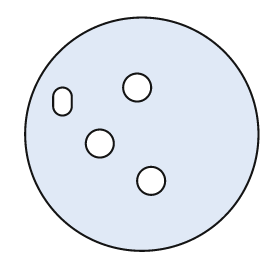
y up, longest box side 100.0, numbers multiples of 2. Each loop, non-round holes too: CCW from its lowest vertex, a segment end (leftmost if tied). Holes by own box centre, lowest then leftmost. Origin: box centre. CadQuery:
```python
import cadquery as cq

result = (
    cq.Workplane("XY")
    .moveTo(0.0, 0.0)
    .circle(50.0)
    .moveTo(4.0, -20.0)
    .circle(6.0)
    .moveTo(-18.0, -4.0)
    .circle(6.0)
    .moveTo(-38.0, 12.0)
    .threePointArc((-34.0, 8.0), (-30.0, 12.0))
    .lineTo(-30.0, 16.0)
    .threePointArc((-34.0, 20.0), (-38.0, 16.0))
    .close()
    .moveTo(-2.0, 20.0)
    .circle(6.0)
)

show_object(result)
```